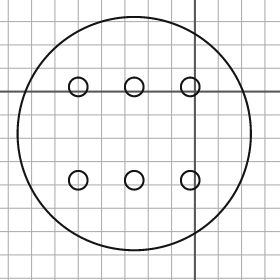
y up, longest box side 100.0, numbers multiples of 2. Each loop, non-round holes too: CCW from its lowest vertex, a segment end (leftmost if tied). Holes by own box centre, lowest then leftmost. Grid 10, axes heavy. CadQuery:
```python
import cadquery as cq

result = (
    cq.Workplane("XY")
    .moveTo(-26.0, -18.0)
    .circle(50.0)
    .moveTo(-50.0, -38.0)
    .circle(4.0)
    .moveTo(-26.0, -38.0)
    .circle(4.0)
    .moveTo(-2.0, -38.0)
    .circle(4.0)
    .moveTo(-50.0, 2.0)
    .circle(4.0)
    .moveTo(-26.0, 2.0)
    .circle(4.0)
    .moveTo(-2.0, 2.0)
    .circle(4.0)
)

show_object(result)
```